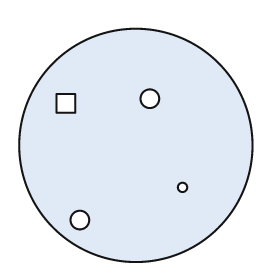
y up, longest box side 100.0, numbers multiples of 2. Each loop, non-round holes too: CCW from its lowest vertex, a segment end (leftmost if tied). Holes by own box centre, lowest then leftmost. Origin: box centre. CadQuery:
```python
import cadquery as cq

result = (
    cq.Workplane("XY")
    .moveTo(0.0, 0.0)
    .circle(50.0)
    .moveTo(-24.0, -32.0)
    .circle(4.0)
    .moveTo(20.0, -18.0)
    .circle(2.0)
    .moveTo(-34.0, 14.0)
    .lineTo(-26.0, 14.0)
    .lineTo(-26.0, 22.0)
    .lineTo(-34.0, 22.0)
    .close()
    .moveTo(6.0, 20.0)
    .circle(4.0)
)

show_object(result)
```